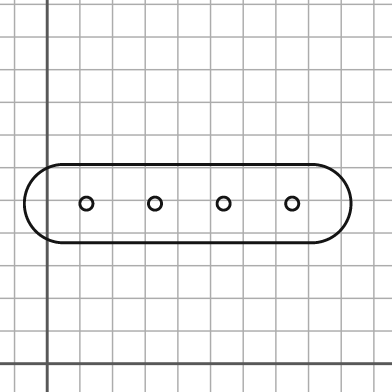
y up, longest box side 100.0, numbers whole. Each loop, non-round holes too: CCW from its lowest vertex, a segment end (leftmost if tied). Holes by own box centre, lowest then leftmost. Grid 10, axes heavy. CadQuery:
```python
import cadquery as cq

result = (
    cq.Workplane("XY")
    .moveTo(5.0, 37.0)
    .lineTo(81.0, 37.0)
    .threePointArc((93.0, 49.0), (81.0, 61.0))
    .lineTo(5.0, 61.0)
    .threePointArc((-7.0, 49.0), (5.0, 37.0))
    .close()
    .moveTo(12.0, 49.0)
    .circle(2.0)
    .moveTo(33.0, 49.0)
    .circle(2.0)
    .moveTo(54.0, 49.0)
    .circle(2.0)
    .moveTo(75.0, 49.0)
    .circle(2.0)
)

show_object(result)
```